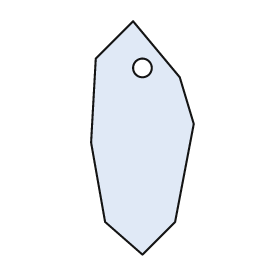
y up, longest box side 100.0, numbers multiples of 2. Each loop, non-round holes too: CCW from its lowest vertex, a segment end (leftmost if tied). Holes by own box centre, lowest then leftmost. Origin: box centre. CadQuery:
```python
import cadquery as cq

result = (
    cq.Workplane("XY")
    .moveTo(0.0, -50.0)
    .lineTo(14.0, -36.0)
    .lineTo(22.0, 6.0)
    .lineTo(16.0, 26.0)
    .lineTo(-4.0, 50.0)
    .lineTo(-20.0, 34.0)
    .lineTo(-22.0, -2.0)
    .lineTo(-16.0, -36.0)
    .close()
    .moveTo(0.0, 30.0)
    .circle(4.0)
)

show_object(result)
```